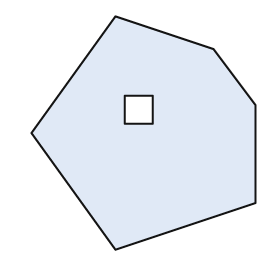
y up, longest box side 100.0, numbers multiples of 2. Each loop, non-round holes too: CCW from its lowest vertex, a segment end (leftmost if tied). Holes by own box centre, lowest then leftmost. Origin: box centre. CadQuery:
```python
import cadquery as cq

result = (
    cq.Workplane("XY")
    .moveTo(-12.0, -50.0)
    .lineTo(48.0, -30.0)
    .lineTo(48.0, 12.0)
    .lineTo(30.0, 36.0)
    .lineTo(-12.0, 50.0)
    .lineTo(-48.0, 0.0)
    .close()
    .moveTo(-8.0, 4.0)
    .lineTo(4.0, 4.0)
    .lineTo(4.0, 16.0)
    .lineTo(-8.0, 16.0)
    .close()
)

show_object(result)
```